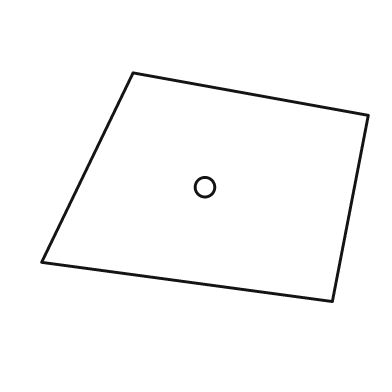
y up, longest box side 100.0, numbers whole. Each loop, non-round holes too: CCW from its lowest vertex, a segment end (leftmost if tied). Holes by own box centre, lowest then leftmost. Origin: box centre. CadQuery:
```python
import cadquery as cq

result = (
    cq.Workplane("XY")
    .moveTo(39.0, -35.0)
    .lineTo(50.0, 22.0)
    .lineTo(-22.0, 35.0)
    .lineTo(-50.0, -23.0)
    .close()
    .moveTo(0.0, 0.0)
    .circle(3.0)
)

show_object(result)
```